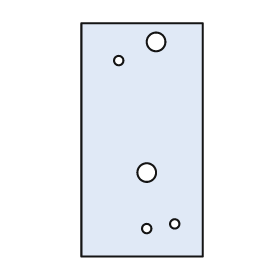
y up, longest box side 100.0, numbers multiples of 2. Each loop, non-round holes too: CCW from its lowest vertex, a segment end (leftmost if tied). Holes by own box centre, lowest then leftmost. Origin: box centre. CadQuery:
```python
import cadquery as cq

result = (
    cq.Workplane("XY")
    .moveTo(-26.0, -50.0)
    .lineTo(26.0, -50.0)
    .lineTo(26.0, 50.0)
    .lineTo(-26.0, 50.0)
    .close()
    .moveTo(2.0, -38.0)
    .circle(2.0)
    .moveTo(14.0, -36.0)
    .circle(2.0)
    .moveTo(2.0, -14.0)
    .circle(4.0)
    .moveTo(-10.0, 34.0)
    .circle(2.0)
    .moveTo(6.0, 42.0)
    .circle(4.0)
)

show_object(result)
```